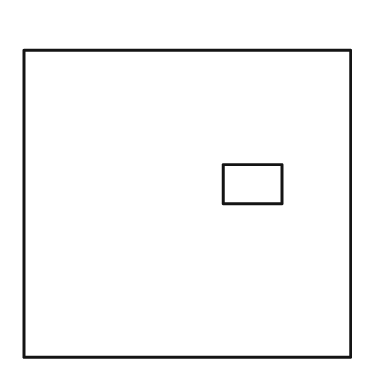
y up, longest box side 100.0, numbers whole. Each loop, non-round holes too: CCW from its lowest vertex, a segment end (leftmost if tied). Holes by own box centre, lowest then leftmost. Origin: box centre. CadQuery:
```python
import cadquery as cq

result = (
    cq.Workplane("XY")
    .moveTo(-50.0, -47.0)
    .lineTo(50.0, -47.0)
    .lineTo(50.0, 47.0)
    .lineTo(-50.0, 47.0)
    .close()
    .moveTo(11.0, 0.0)
    .lineTo(29.0, 0.0)
    .lineTo(29.0, 12.0)
    .lineTo(11.0, 12.0)
    .close()
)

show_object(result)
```